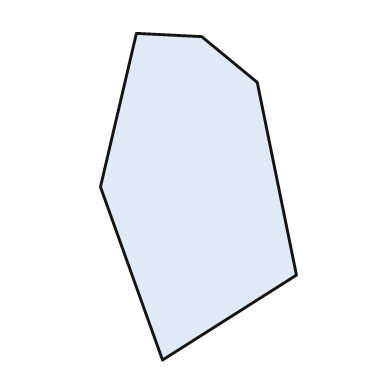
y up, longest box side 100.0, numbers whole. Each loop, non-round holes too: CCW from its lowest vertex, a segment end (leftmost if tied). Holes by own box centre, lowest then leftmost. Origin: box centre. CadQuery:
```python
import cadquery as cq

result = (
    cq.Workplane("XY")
    .moveTo(-11.0, -50.0)
    .lineTo(30.0, -24.0)
    .lineTo(18.0, 35.0)
    .lineTo(1.0, 49.0)
    .lineTo(-19.0, 50.0)
    .lineTo(-30.0, 3.0)
    .close()
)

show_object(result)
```